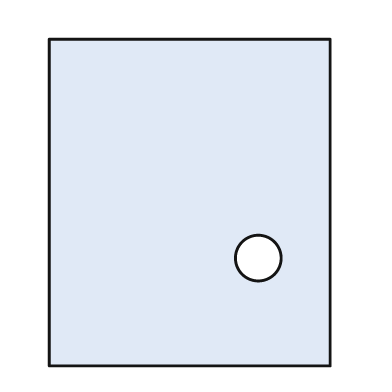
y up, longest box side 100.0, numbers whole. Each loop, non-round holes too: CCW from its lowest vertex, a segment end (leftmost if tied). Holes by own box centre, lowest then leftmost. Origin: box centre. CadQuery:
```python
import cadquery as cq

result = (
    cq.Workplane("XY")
    .moveTo(-43.0, -50.0)
    .lineTo(43.0, -50.0)
    .lineTo(43.0, 50.0)
    .lineTo(-43.0, 50.0)
    .close()
    .moveTo(21.0, -17.0)
    .circle(7.0)
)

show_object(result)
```